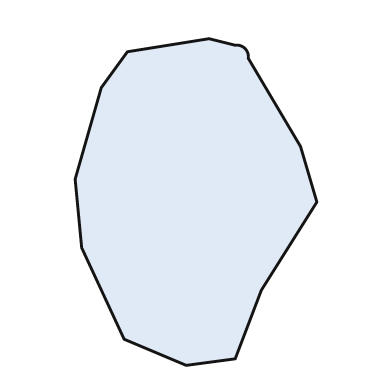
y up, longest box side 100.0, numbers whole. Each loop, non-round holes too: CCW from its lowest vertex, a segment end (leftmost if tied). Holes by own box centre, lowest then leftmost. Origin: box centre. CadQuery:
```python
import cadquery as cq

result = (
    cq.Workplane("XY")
    .moveTo(-3.0, -50.0)
    .lineTo(12.0, -48.0)
    .lineTo(20.0, -27.0)
    .lineTo(37.0, 0.0)
    .lineTo(32.0, 17.0)
    .lineTo(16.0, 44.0)
    .threePointArc((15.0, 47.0), (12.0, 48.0))
    .lineTo(4.0, 50.0)
    .lineTo(-21.0, 46.0)
    .lineTo(-29.0, 35.0)
    .lineTo(-37.0, 7.0)
    .lineTo(-35.0, -14.0)
    .lineTo(-22.0, -42.0)
    .close()
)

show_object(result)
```